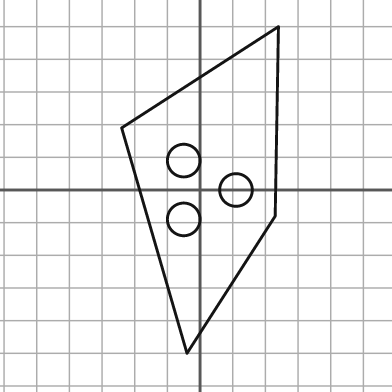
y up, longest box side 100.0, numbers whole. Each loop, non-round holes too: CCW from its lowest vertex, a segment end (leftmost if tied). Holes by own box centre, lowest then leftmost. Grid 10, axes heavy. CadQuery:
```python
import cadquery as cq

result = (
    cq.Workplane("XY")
    .moveTo(-4.0, -50.0)
    .lineTo(23.0, -8.0)
    .lineTo(24.0, 50.0)
    .lineTo(-24.0, 19.0)
    .close()
    .moveTo(-5.0, -9.0)
    .circle(5.0)
    .moveTo(11.0, 0.0)
    .circle(5.0)
    .moveTo(-5.0, 9.0)
    .circle(5.0)
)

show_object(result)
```